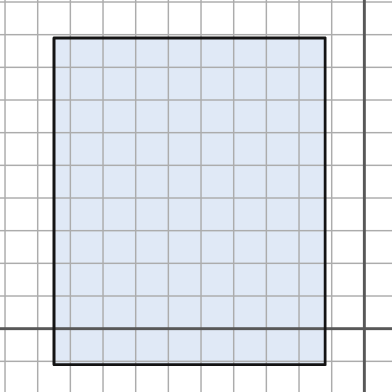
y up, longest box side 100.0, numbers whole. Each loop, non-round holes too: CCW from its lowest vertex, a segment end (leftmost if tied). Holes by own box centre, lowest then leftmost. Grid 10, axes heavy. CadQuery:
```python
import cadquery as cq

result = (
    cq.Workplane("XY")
    .moveTo(-95.0, -11.0)
    .lineTo(-12.0, -11.0)
    .lineTo(-12.0, 89.0)
    .lineTo(-95.0, 89.0)
    .close()
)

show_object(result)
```